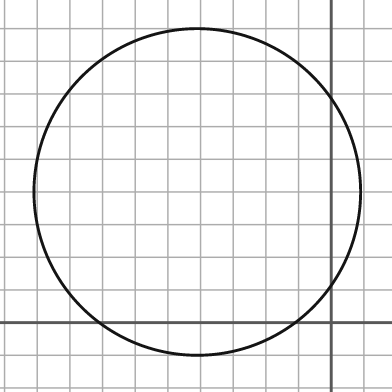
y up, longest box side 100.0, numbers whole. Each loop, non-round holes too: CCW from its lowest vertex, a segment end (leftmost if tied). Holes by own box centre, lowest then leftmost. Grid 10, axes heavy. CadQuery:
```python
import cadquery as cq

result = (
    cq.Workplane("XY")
    .moveTo(-41.0, 40.0)
    .circle(50.0)
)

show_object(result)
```